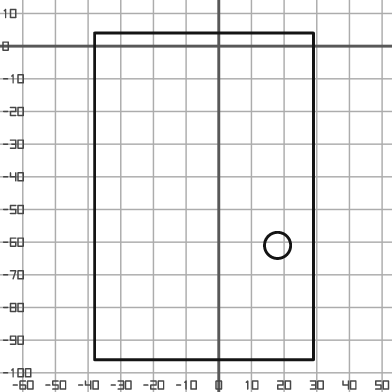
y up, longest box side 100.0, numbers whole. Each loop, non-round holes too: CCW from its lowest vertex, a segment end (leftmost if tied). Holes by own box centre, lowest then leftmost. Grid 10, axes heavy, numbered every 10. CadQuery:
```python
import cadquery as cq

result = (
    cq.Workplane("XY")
    .moveTo(-38.0, -96.0)
    .lineTo(29.0, -96.0)
    .lineTo(29.0, 4.0)
    .lineTo(-38.0, 4.0)
    .close()
    .moveTo(18.0, -61.0)
    .circle(4.0)
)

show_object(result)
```